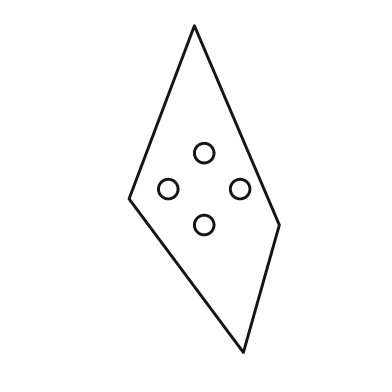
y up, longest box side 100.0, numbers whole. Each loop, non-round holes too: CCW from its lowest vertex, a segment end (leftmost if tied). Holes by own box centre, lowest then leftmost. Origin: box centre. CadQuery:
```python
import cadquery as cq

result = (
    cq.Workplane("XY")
    .moveTo(12.0, -50.0)
    .lineTo(23.0, -11.0)
    .lineTo(-3.0, 50.0)
    .lineTo(-23.0, -3.0)
    .close()
    .moveTo(0.0, -11.0)
    .circle(3.0)
    .moveTo(-11.0, 0.0)
    .circle(3.0)
    .moveTo(11.0, 0.0)
    .circle(3.0)
    .moveTo(0.0, 11.0)
    .circle(3.0)
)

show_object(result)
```